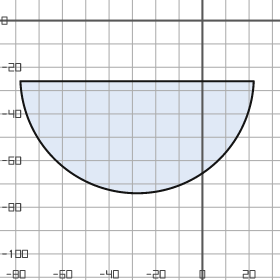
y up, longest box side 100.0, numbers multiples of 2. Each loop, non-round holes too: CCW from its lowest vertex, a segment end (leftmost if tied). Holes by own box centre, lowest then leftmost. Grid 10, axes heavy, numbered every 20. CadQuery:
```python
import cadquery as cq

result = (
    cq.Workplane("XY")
    .moveTo(-78.0, -26.0)
    .threePointArc((-28.0, -74.0), (22.0, -26.0))
    .close()
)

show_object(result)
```